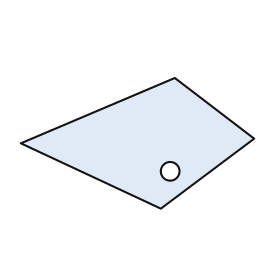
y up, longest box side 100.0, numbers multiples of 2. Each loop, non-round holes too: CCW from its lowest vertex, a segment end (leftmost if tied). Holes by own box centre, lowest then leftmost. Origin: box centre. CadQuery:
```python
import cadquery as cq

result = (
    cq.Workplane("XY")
    .moveTo(10.0, -28.0)
    .lineTo(50.0, 2.0)
    .lineTo(16.0, 28.0)
    .lineTo(-50.0, 0.0)
    .close()
    .moveTo(14.0, -12.0)
    .circle(4.0)
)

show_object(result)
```